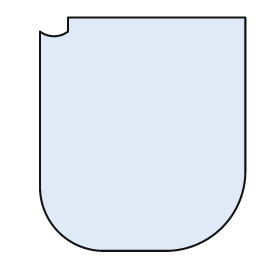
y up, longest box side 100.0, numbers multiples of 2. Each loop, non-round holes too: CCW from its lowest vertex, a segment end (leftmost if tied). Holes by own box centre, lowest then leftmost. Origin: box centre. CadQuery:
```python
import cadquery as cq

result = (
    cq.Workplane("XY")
    .moveTo(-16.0, -50.0)
    .lineTo(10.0, -50.0)
    .threePointArc((34.0, -40.0), (44.0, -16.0))
    .lineTo(44.0, 50.0)
    .lineTo(-32.0, 50.0)
    .lineTo(-32.0, 44.0)
    .threePointArc((-38.0, 42.0), (-44.0, 44.0))
    .lineTo(-44.0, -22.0)
    .threePointArc((-36.0, -42.0), (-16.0, -50.0))
    .close()
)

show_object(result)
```